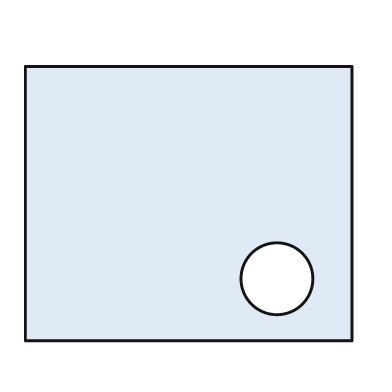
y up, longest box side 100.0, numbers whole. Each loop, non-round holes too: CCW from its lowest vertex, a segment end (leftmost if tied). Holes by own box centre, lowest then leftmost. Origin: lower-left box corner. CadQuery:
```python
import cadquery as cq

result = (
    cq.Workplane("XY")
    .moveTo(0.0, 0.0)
    .lineTo(100.0, 0.0)
    .lineTo(100.0, 84.0)
    .lineTo(0.0, 84.0)
    .close()
    .moveTo(77.0, 19.0)
    .circle(11.0)
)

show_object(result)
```